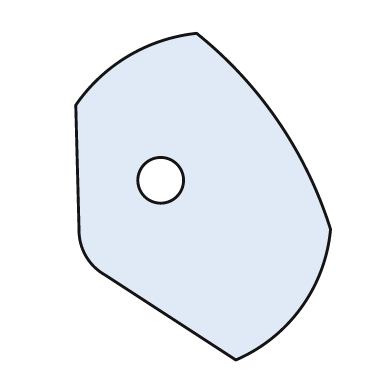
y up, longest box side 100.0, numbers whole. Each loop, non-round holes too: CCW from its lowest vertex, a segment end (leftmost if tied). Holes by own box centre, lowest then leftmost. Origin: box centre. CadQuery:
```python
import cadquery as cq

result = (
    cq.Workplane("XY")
    .moveTo(10.0, -50.0)
    .threePointArc((30.0, -34.0), (39.0, -10.0))
    .threePointArc((23.0, 23.0), (-2.0, 50.0))
    .threePointArc((-23.0, 43.0), (-39.0, 28.0))
    .lineTo(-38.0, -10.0)
    .threePointArc((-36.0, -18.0), (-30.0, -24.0))
    .close()
    .moveTo(-13.0, 5.0)
    .circle(7.0)
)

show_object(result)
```